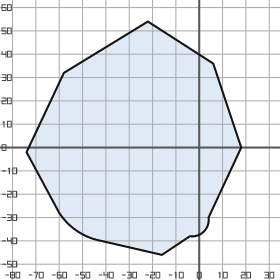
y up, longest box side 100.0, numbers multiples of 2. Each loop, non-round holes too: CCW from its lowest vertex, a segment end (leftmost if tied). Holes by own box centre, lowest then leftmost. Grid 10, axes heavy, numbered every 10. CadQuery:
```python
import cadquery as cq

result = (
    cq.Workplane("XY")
    .moveTo(-16.0, -46.0)
    .lineTo(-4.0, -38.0)
    .threePointArc((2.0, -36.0), (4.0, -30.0))
    .lineTo(18.0, 0.0)
    .lineTo(6.0, 36.0)
    .lineTo(-22.0, 54.0)
    .lineTo(-58.0, 32.0)
    .lineTo(-74.0, -2.0)
    .lineTo(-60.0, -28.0)
    .threePointArc((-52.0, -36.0), (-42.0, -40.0))
    .close()
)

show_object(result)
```